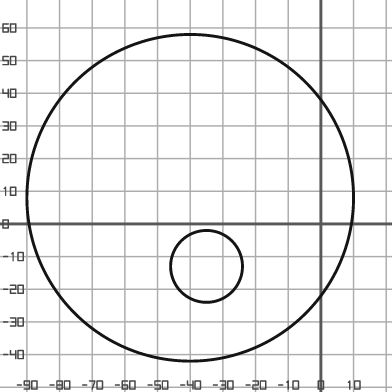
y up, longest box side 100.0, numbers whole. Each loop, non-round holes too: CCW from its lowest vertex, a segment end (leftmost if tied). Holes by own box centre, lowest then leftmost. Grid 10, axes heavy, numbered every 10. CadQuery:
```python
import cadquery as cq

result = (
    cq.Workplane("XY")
    .moveTo(-40.0, 8.0)
    .circle(50.0)
    .moveTo(-35.0, -13.0)
    .circle(11.0)
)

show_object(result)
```